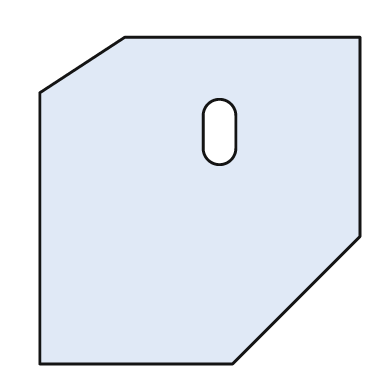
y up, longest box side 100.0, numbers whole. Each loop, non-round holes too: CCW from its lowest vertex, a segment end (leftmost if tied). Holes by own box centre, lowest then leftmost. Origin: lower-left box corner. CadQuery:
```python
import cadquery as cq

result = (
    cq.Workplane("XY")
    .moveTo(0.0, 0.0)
    .lineTo(59.0, 0.0)
    .lineTo(98.0, 39.0)
    .lineTo(98.0, 100.0)
    .lineTo(26.0, 100.0)
    .lineTo(0.0, 83.0)
    .close()
    .moveTo(50.0, 66.0)
    .threePointArc((55.0, 61.0), (60.0, 66.0))
    .lineTo(60.0, 76.0)
    .threePointArc((55.0, 81.0), (50.0, 76.0))
    .close()
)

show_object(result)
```